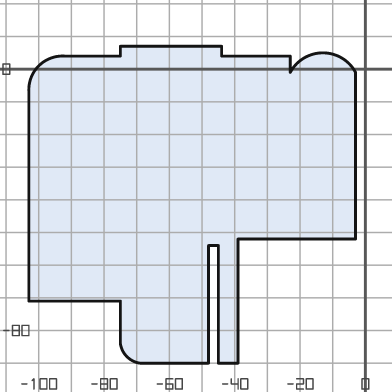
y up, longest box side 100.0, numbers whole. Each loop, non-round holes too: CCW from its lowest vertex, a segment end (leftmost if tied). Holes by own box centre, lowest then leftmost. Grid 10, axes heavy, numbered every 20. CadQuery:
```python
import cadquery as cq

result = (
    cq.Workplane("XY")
    .moveTo(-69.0, -90.0)
    .lineTo(-48.0, -90.0)
    .lineTo(-48.0, -54.0)
    .lineTo(-45.0, -54.0)
    .lineTo(-45.0, -90.0)
    .lineTo(-39.0, -90.0)
    .lineTo(-39.0, -52.0)
    .lineTo(-3.0, -52.0)
    .lineTo(-3.0, -1.0)
    .threePointArc((-13.0, 5.0), (-23.0, -1.0))
    .lineTo(-23.0, 4.0)
    .lineTo(-44.0, 4.0)
    .lineTo(-44.0, 7.0)
    .lineTo(-75.0, 7.0)
    .lineTo(-75.0, 4.0)
    .lineTo(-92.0, 4.0)
    .threePointArc((-100.0, 1.0), (-103.0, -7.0))
    .lineTo(-103.0, -71.0)
    .lineTo(-75.0, -71.0)
    .lineTo(-75.0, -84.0)
    .threePointArc((-73.0, -88.0), (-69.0, -90.0))
    .close()
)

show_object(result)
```